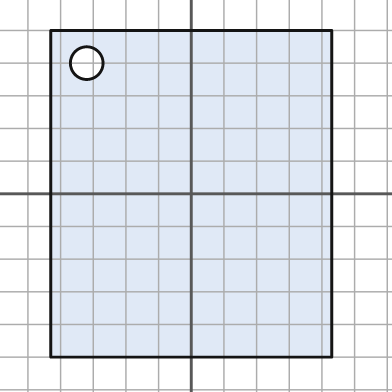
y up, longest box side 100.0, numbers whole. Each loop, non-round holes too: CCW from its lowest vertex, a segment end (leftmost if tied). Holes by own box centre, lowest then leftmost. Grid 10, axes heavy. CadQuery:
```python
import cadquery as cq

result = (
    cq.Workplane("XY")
    .moveTo(-43.0, -50.0)
    .lineTo(43.0, -50.0)
    .lineTo(43.0, 50.0)
    .lineTo(-43.0, 50.0)
    .close()
    .moveTo(-32.0, 40.0)
    .circle(5.0)
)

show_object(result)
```